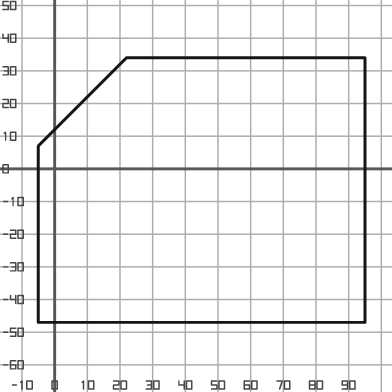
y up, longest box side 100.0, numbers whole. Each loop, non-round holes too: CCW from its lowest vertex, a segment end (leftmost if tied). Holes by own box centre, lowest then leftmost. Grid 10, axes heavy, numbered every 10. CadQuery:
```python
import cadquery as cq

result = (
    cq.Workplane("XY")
    .moveTo(-5.0, -47.0)
    .lineTo(95.0, -47.0)
    .lineTo(95.0, 34.0)
    .lineTo(22.0, 34.0)
    .lineTo(-5.0, 7.0)
    .close()
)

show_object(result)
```